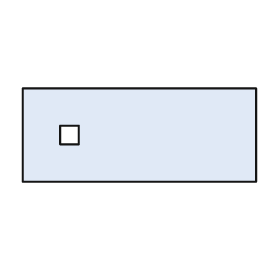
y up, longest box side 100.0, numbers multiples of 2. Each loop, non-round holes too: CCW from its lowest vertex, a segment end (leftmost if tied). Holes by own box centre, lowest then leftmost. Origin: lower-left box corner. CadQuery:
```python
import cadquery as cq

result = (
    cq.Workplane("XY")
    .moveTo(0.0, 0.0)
    .lineTo(100.0, 0.0)
    .lineTo(100.0, 40.0)
    .lineTo(0.0, 40.0)
    .close()
    .moveTo(16.0, 16.0)
    .lineTo(24.0, 16.0)
    .lineTo(24.0, 24.0)
    .lineTo(16.0, 24.0)
    .close()
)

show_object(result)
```